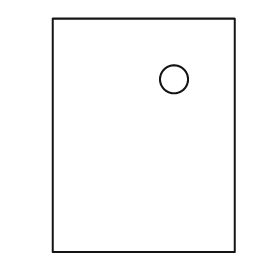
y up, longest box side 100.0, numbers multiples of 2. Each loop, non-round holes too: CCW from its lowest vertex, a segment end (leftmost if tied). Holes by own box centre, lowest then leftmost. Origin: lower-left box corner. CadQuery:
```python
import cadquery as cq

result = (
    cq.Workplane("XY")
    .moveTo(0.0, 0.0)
    .lineTo(78.0, 0.0)
    .lineTo(78.0, 100.0)
    .lineTo(0.0, 100.0)
    .close()
    .moveTo(52.0, 74.0)
    .circle(6.0)
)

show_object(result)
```